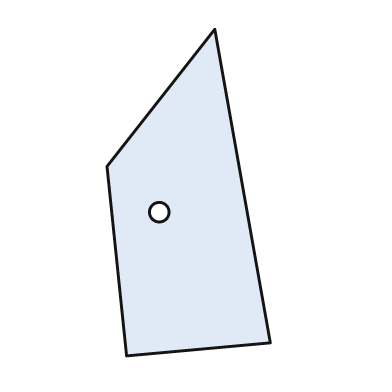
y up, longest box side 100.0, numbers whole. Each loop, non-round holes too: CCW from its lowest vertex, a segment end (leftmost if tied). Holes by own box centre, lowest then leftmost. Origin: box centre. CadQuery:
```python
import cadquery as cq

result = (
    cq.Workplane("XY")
    .moveTo(-19.0, -50.0)
    .lineTo(25.0, -46.0)
    .lineTo(8.0, 50.0)
    .lineTo(-25.0, 8.0)
    .close()
    .moveTo(-9.0, -6.0)
    .circle(3.0)
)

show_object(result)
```